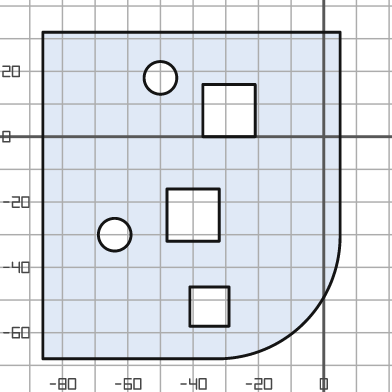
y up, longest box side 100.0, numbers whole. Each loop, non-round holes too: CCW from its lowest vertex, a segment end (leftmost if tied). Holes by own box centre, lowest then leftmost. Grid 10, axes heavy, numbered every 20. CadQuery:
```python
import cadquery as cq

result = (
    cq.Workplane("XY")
    .moveTo(-86.0, -68.0)
    .lineTo(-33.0, -68.0)
    .threePointArc((-6.0, -57.0), (5.0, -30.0))
    .lineTo(5.0, 32.0)
    .lineTo(-86.0, 32.0)
    .close()
    .moveTo(-41.0, -58.0)
    .lineTo(-29.0, -58.0)
    .lineTo(-29.0, -46.0)
    .lineTo(-41.0, -46.0)
    .close()
    .moveTo(-64.0, -30.0)
    .circle(5.0)
    .moveTo(-48.0, -32.0)
    .lineTo(-32.0, -32.0)
    .lineTo(-32.0, -16.0)
    .lineTo(-48.0, -16.0)
    .close()
    .moveTo(-37.0, 0.0)
    .lineTo(-21.0, 0.0)
    .lineTo(-21.0, 16.0)
    .lineTo(-37.0, 16.0)
    .close()
    .moveTo(-50.0, 18.0)
    .circle(5.0)
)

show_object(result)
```